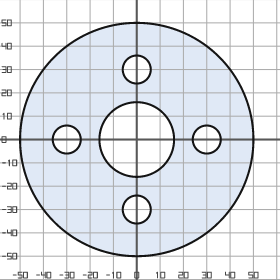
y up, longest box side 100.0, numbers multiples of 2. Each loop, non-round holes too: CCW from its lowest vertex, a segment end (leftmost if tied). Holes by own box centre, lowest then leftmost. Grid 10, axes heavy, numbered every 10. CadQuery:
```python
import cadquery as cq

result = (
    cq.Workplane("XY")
    .moveTo(0.0, 0.0)
    .circle(50.0)
    .moveTo(0.0, -30.0)
    .circle(6.0)
    .moveTo(-30.0, 0.0)
    .circle(6.0)
    .moveTo(0.0, 0.0)
    .circle(16.0)
    .moveTo(30.0, 0.0)
    .circle(6.0)
    .moveTo(0.0, 30.0)
    .circle(6.0)
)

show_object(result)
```